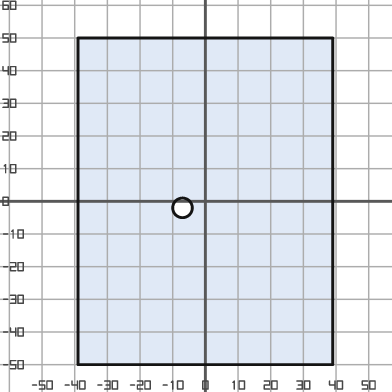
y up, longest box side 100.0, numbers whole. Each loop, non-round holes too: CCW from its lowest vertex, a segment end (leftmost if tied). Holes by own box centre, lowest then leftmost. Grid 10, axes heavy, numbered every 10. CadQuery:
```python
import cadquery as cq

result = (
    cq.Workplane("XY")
    .moveTo(-39.0, -50.0)
    .lineTo(39.0, -50.0)
    .lineTo(39.0, 50.0)
    .lineTo(-39.0, 50.0)
    .close()
    .moveTo(-7.0, -2.0)
    .circle(3.0)
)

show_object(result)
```